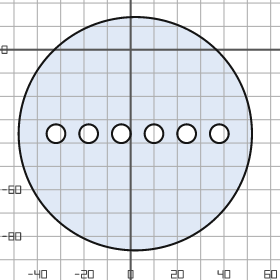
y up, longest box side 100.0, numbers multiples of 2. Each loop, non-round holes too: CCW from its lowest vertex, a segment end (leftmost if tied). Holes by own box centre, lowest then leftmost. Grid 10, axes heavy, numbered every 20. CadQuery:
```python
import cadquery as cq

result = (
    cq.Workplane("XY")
    .moveTo(2.0, -36.0)
    .circle(50.0)
    .moveTo(-32.0, -36.0)
    .circle(4.0)
    .moveTo(-18.0, -36.0)
    .circle(4.0)
    .moveTo(-4.0, -36.0)
    .circle(4.0)
    .moveTo(10.0, -36.0)
    .circle(4.0)
    .moveTo(24.0, -36.0)
    .circle(4.0)
    .moveTo(38.0, -36.0)
    .circle(4.0)
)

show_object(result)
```